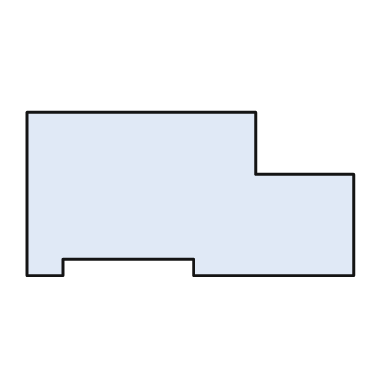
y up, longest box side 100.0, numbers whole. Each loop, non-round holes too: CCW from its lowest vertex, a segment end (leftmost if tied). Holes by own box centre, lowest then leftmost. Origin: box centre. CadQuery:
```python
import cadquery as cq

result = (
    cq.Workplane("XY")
    .moveTo(-50.0, -25.0)
    .lineTo(-39.0, -25.0)
    .lineTo(-39.0, -20.0)
    .lineTo(1.0, -20.0)
    .lineTo(1.0, -25.0)
    .lineTo(50.0, -25.0)
    .lineTo(50.0, 6.0)
    .lineTo(20.0, 6.0)
    .lineTo(20.0, 25.0)
    .lineTo(-50.0, 25.0)
    .close()
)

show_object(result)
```